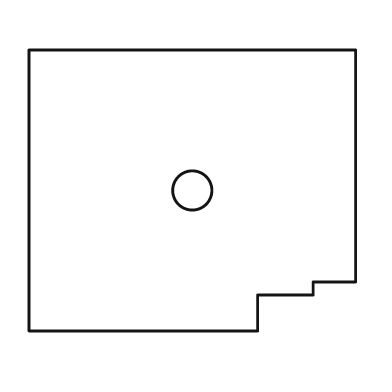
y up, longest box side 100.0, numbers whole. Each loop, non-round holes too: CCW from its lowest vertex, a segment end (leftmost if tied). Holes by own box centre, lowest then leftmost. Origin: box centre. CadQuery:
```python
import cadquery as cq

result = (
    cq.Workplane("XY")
    .moveTo(-50.0, -43.0)
    .lineTo(20.0, -43.0)
    .lineTo(20.0, -32.0)
    .lineTo(37.0, -32.0)
    .lineTo(37.0, -28.0)
    .lineTo(50.0, -28.0)
    .lineTo(50.0, 43.0)
    .lineTo(-50.0, 43.0)
    .close()
    .moveTo(0.0, 0.0)
    .circle(6.0)
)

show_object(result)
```